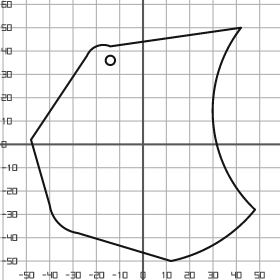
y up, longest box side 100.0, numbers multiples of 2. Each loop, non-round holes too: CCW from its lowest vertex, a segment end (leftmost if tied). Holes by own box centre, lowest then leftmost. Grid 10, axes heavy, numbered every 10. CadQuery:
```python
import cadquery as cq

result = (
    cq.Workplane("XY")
    .moveTo(12.0, -50.0)
    .threePointArc((32.0, -42.0), (48.0, -28.0))
    .threePointArc((30.0, 10.0), (42.0, 50.0))
    .lineTo(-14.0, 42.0)
    .threePointArc((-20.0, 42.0), (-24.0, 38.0))
    .lineTo(-48.0, 2.0)
    .lineTo(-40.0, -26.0)
    .threePointArc((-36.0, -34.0), (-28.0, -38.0))
    .close()
    .moveTo(-14.0, 36.0)
    .circle(2.0)
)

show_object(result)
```